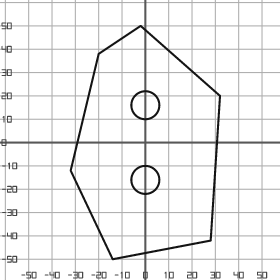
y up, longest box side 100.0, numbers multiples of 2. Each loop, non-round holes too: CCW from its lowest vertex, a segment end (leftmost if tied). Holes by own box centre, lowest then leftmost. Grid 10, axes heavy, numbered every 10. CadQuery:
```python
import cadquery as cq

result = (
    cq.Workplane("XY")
    .moveTo(-14.0, -50.0)
    .lineTo(28.0, -42.0)
    .lineTo(32.0, 20.0)
    .lineTo(-2.0, 50.0)
    .lineTo(-20.0, 38.0)
    .lineTo(-32.0, -12.0)
    .close()
    .moveTo(0.0, -16.0)
    .circle(6.0)
    .moveTo(0.0, 16.0)
    .circle(6.0)
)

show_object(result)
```